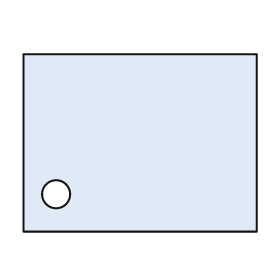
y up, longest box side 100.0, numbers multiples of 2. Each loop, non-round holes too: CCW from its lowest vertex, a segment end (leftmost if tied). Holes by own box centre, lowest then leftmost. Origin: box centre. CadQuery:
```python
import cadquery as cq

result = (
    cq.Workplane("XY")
    .moveTo(-50.0, -38.0)
    .lineTo(50.0, -38.0)
    .lineTo(50.0, 38.0)
    .lineTo(-50.0, 38.0)
    .close()
    .moveTo(-36.0, -22.0)
    .circle(6.0)
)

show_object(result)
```